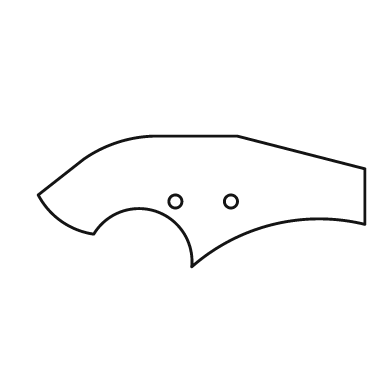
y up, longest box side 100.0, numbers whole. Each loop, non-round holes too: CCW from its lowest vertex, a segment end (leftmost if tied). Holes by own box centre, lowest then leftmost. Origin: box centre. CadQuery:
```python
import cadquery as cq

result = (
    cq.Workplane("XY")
    .moveTo(-3.0, -20.0)
    .threePointArc((22.0, -7.0), (50.0, -7.0))
    .lineTo(50.0, 10.0)
    .lineTo(11.0, 20.0)
    .lineTo(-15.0, 20.0)
    .threePointArc((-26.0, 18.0), (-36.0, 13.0))
    .lineTo(-50.0, 2.0)
    .threePointArc((-43.0, -6.0), (-33.0, -10.0))
    .threePointArc((-14.0, -3.0), (-3.0, -20.0))
    .close()
    .moveTo(-8.0, 0.0)
    .circle(2.0)
    .moveTo(9.0, 0.0)
    .circle(2.0)
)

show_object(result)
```